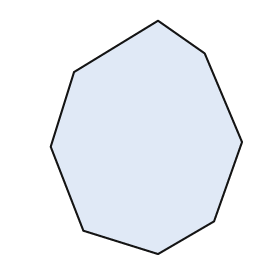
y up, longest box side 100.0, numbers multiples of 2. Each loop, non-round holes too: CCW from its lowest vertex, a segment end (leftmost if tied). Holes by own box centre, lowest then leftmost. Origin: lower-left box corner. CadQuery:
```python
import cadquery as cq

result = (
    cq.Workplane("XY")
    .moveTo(46.0, 0.0)
    .lineTo(70.0, 14.0)
    .lineTo(82.0, 48.0)
    .lineTo(66.0, 86.0)
    .lineTo(46.0, 100.0)
    .lineTo(10.0, 78.0)
    .lineTo(0.0, 46.0)
    .lineTo(14.0, 10.0)
    .close()
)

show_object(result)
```